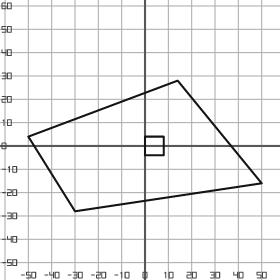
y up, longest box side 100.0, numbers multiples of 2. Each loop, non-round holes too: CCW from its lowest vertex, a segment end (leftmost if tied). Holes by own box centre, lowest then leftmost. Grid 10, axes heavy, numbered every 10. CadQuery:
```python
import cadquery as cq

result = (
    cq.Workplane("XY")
    .moveTo(-30.0, -28.0)
    .lineTo(50.0, -16.0)
    .lineTo(14.0, 28.0)
    .lineTo(-50.0, 4.0)
    .close()
    .moveTo(0.0, -4.0)
    .lineTo(8.0, -4.0)
    .lineTo(8.0, 4.0)
    .lineTo(0.0, 4.0)
    .close()
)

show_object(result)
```